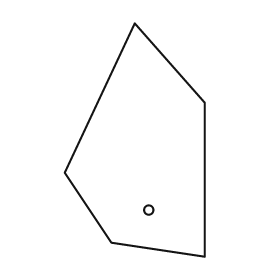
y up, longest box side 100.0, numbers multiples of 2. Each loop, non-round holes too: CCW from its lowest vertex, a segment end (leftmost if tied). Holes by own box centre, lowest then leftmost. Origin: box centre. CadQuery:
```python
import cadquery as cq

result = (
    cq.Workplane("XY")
    .moveTo(30.0, -50.0)
    .lineTo(30.0, 16.0)
    .lineTo(0.0, 50.0)
    .lineTo(-30.0, -14.0)
    .lineTo(-10.0, -44.0)
    .close()
    .moveTo(6.0, -30.0)
    .circle(2.0)
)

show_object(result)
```